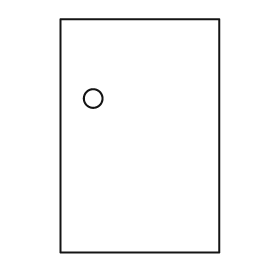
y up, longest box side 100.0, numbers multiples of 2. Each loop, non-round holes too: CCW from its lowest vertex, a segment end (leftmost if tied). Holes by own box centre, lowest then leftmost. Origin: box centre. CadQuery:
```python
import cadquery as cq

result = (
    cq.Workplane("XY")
    .moveTo(-34.0, -50.0)
    .lineTo(34.0, -50.0)
    .lineTo(34.0, 50.0)
    .lineTo(-34.0, 50.0)
    .close()
    .moveTo(-20.0, 16.0)
    .circle(4.0)
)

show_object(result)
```